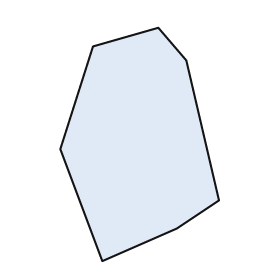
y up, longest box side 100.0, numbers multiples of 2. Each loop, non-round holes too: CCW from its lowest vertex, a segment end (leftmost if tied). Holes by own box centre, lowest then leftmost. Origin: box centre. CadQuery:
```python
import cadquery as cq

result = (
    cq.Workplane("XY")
    .moveTo(-16.0, -50.0)
    .lineTo(16.0, -36.0)
    .lineTo(34.0, -24.0)
    .lineTo(20.0, 36.0)
    .lineTo(8.0, 50.0)
    .lineTo(-20.0, 42.0)
    .lineTo(-34.0, -2.0)
    .close()
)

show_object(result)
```